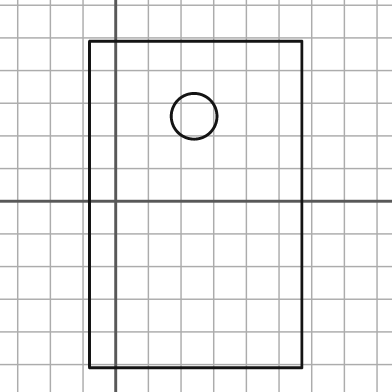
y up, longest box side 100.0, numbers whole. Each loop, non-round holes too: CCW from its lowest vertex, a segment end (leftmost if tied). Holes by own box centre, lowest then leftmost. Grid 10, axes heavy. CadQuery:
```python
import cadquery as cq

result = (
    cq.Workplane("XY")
    .moveTo(-8.0, -51.0)
    .lineTo(57.0, -51.0)
    .lineTo(57.0, 49.0)
    .lineTo(-8.0, 49.0)
    .close()
    .moveTo(24.0, 26.0)
    .circle(7.0)
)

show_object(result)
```